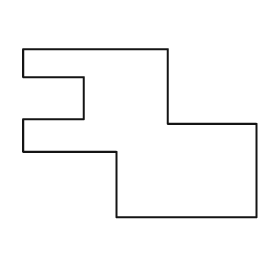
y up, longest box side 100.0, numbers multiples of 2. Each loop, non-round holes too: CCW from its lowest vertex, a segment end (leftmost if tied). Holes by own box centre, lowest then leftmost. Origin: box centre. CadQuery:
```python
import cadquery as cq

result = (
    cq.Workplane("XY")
    .moveTo(-10.0, -36.0)
    .lineTo(50.0, -36.0)
    .lineTo(50.0, 4.0)
    .lineTo(12.0, 4.0)
    .lineTo(12.0, 36.0)
    .lineTo(-50.0, 36.0)
    .lineTo(-50.0, 24.0)
    .lineTo(-24.0, 24.0)
    .lineTo(-24.0, 6.0)
    .lineTo(-50.0, 6.0)
    .lineTo(-50.0, -8.0)
    .lineTo(-10.0, -8.0)
    .close()
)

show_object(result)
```